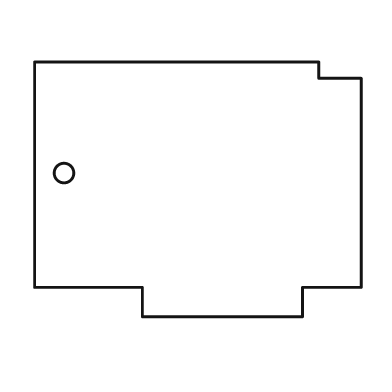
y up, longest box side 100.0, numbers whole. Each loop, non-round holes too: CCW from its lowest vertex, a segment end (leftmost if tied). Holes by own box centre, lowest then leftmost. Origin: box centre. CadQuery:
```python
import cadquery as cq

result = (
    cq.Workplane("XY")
    .moveTo(-17.0, -39.0)
    .lineTo(32.0, -39.0)
    .lineTo(32.0, -30.0)
    .lineTo(50.0, -30.0)
    .lineTo(50.0, 34.0)
    .lineTo(37.0, 34.0)
    .lineTo(37.0, 39.0)
    .lineTo(-50.0, 39.0)
    .lineTo(-50.0, -30.0)
    .lineTo(-17.0, -30.0)
    .close()
    .moveTo(-41.0, 5.0)
    .circle(3.0)
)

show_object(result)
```